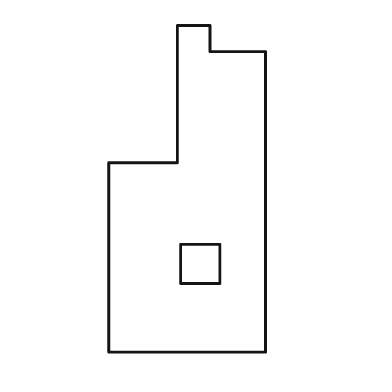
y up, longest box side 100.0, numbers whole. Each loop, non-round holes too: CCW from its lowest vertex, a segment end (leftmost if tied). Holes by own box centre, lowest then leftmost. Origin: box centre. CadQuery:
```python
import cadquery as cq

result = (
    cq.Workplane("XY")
    .moveTo(-24.0, -50.0)
    .lineTo(24.0, -50.0)
    .lineTo(24.0, 42.0)
    .lineTo(7.0, 42.0)
    .lineTo(7.0, 50.0)
    .lineTo(-3.0, 50.0)
    .lineTo(-3.0, 8.0)
    .lineTo(-24.0, 8.0)
    .close()
    .moveTo(-2.0, -29.0)
    .lineTo(10.0, -29.0)
    .lineTo(10.0, -17.0)
    .lineTo(-2.0, -17.0)
    .close()
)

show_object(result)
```